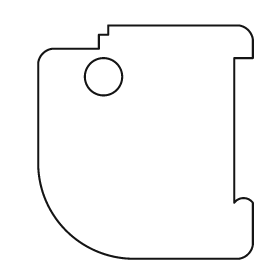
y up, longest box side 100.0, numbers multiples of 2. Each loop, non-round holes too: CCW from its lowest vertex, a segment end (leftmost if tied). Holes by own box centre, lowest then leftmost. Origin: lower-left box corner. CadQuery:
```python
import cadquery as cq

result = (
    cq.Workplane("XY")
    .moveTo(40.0, 0.0)
    .lineTo(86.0, 0.0)
    .threePointArc((90.0, 2.0), (92.0, 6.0))
    .lineTo(92.0, 24.0)
    .threePointArc((88.0, 26.0), (84.0, 24.0))
    .lineTo(84.0, 86.0)
    .lineTo(92.0, 86.0)
    .lineTo(92.0, 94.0)
    .threePointArc((90.0, 98.0), (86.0, 100.0))
    .lineTo(30.0, 100.0)
    .lineTo(30.0, 96.0)
    .lineTo(26.0, 96.0)
    .lineTo(26.0, 90.0)
    .lineTo(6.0, 90.0)
    .threePointArc((2.0, 88.0), (0.0, 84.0))
    .lineTo(0.0, 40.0)
    .threePointArc((12.0, 12.0), (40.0, 0.0))
    .close()
    .moveTo(28.0, 78.0)
    .circle(8.0)
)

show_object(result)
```